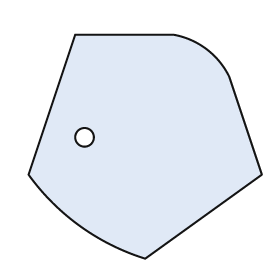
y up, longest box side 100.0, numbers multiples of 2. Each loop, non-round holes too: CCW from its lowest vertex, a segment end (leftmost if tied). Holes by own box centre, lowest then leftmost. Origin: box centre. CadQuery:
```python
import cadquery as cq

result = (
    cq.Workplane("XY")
    .moveTo(0.0, -48.0)
    .lineTo(50.0, -12.0)
    .lineTo(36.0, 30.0)
    .threePointArc((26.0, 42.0), (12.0, 48.0))
    .lineTo(-30.0, 48.0)
    .lineTo(-50.0, -12.0)
    .threePointArc((-28.0, -34.0), (0.0, -48.0))
    .close()
    .moveTo(-26.0, 4.0)
    .circle(4.0)
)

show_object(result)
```